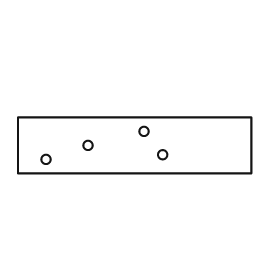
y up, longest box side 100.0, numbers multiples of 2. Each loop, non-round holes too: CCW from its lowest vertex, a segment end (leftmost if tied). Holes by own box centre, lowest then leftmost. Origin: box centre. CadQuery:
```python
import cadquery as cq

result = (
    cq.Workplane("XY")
    .moveTo(-50.0, -12.0)
    .lineTo(50.0, -12.0)
    .lineTo(50.0, 12.0)
    .lineTo(-50.0, 12.0)
    .close()
    .moveTo(-38.0, -6.0)
    .circle(2.0)
    .moveTo(12.0, -4.0)
    .circle(2.0)
    .moveTo(-20.0, 0.0)
    .circle(2.0)
    .moveTo(4.0, 6.0)
    .circle(2.0)
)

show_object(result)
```